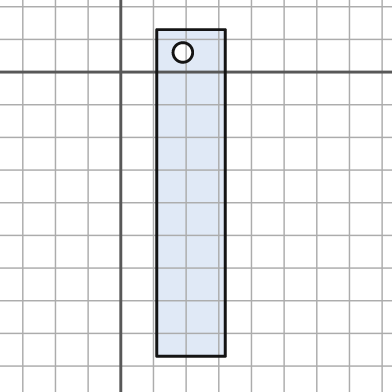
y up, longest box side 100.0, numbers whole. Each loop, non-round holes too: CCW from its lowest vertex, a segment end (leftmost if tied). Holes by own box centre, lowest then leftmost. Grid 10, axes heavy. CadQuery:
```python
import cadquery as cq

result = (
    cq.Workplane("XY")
    .moveTo(11.0, -87.0)
    .lineTo(32.0, -87.0)
    .lineTo(32.0, 13.0)
    .lineTo(11.0, 13.0)
    .close()
    .moveTo(19.0, 6.0)
    .circle(3.0)
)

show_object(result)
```